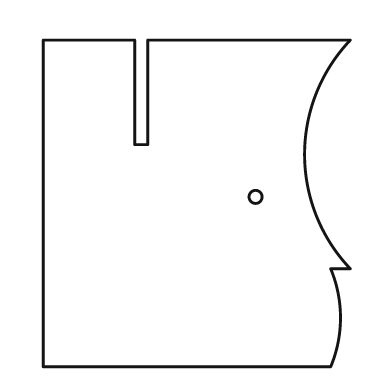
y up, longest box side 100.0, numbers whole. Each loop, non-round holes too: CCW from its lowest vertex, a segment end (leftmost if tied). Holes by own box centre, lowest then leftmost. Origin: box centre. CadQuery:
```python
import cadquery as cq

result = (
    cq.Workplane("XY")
    .moveTo(-47.0, -50.0)
    .lineTo(41.0, -50.0)
    .threePointArc((44.0, -35.0), (41.0, -20.0))
    .lineTo(47.0, -20.0)
    .threePointArc((33.0, 15.0), (47.0, 50.0))
    .lineTo(-15.0, 50.0)
    .lineTo(-15.0, 18.0)
    .lineTo(-19.0, 18.0)
    .lineTo(-19.0, 50.0)
    .lineTo(-47.0, 50.0)
    .close()
    .moveTo(18.0, 2.0)
    .circle(2.0)
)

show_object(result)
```